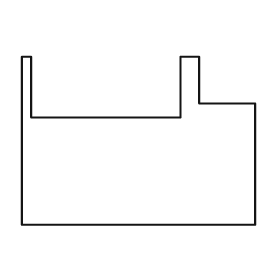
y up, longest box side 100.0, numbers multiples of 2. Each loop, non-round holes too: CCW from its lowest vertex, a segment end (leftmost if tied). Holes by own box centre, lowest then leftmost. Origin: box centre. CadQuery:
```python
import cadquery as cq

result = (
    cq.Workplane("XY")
    .moveTo(-50.0, -36.0)
    .lineTo(50.0, -36.0)
    .lineTo(50.0, 16.0)
    .lineTo(26.0, 16.0)
    .lineTo(26.0, 36.0)
    .lineTo(18.0, 36.0)
    .lineTo(18.0, 10.0)
    .lineTo(-46.0, 10.0)
    .lineTo(-46.0, 36.0)
    .lineTo(-50.0, 36.0)
    .close()
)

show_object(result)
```